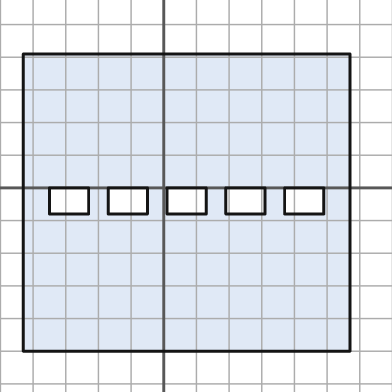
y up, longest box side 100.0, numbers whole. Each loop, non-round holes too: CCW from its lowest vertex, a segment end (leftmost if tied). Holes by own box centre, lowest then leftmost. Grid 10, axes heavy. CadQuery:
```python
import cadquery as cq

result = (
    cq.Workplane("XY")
    .moveTo(-43.0, -50.0)
    .lineTo(57.0, -50.0)
    .lineTo(57.0, 41.0)
    .lineTo(-43.0, 41.0)
    .close()
    .moveTo(-35.0, -8.0)
    .lineTo(-23.0, -8.0)
    .lineTo(-23.0, 0.0)
    .lineTo(-35.0, 0.0)
    .close()
    .moveTo(-17.0, -8.0)
    .lineTo(-5.0, -8.0)
    .lineTo(-5.0, 0.0)
    .lineTo(-17.0, 0.0)
    .close()
    .moveTo(1.0, -8.0)
    .lineTo(13.0, -8.0)
    .lineTo(13.0, 0.0)
    .lineTo(1.0, 0.0)
    .close()
    .moveTo(19.0, -8.0)
    .lineTo(31.0, -8.0)
    .lineTo(31.0, 0.0)
    .lineTo(19.0, 0.0)
    .close()
    .moveTo(37.0, -8.0)
    .lineTo(49.0, -8.0)
    .lineTo(49.0, 0.0)
    .lineTo(37.0, 0.0)
    .close()
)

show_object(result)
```